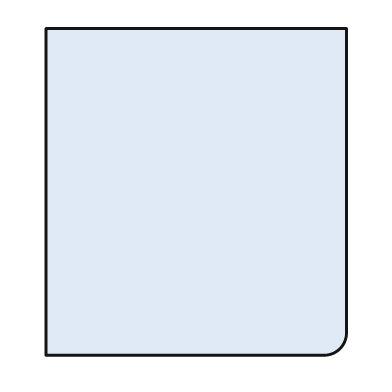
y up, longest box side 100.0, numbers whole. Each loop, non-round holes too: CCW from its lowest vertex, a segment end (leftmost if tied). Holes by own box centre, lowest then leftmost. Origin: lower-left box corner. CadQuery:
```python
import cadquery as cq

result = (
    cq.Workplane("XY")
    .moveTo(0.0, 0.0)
    .lineTo(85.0, 0.0)
    .threePointArc((90.0, 2.0), (92.0, 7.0))
    .lineTo(92.0, 100.0)
    .lineTo(0.0, 100.0)
    .close()
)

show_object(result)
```